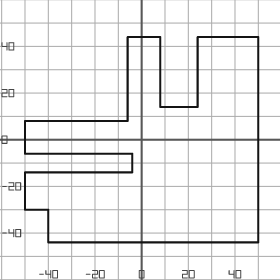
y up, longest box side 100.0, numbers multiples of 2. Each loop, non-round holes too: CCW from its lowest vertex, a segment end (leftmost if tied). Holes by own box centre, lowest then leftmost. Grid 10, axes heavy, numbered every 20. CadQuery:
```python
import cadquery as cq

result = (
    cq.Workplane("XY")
    .moveTo(-40.0, -44.0)
    .lineTo(50.0, -44.0)
    .lineTo(50.0, 44.0)
    .lineTo(24.0, 44.0)
    .lineTo(24.0, 14.0)
    .lineTo(8.0, 14.0)
    .lineTo(8.0, 44.0)
    .lineTo(-6.0, 44.0)
    .lineTo(-6.0, 8.0)
    .lineTo(-50.0, 8.0)
    .lineTo(-50.0, -6.0)
    .lineTo(-4.0, -6.0)
    .lineTo(-4.0, -14.0)
    .lineTo(-50.0, -14.0)
    .lineTo(-50.0, -30.0)
    .lineTo(-40.0, -30.0)
    .close()
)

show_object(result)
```